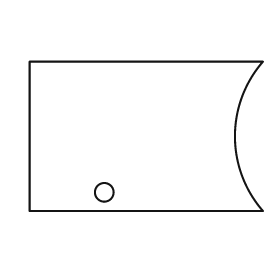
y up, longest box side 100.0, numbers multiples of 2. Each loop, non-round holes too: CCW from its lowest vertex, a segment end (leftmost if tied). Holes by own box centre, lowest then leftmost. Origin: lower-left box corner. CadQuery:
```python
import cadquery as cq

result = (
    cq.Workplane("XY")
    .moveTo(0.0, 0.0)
    .lineTo(100.0, 0.0)
    .threePointArc((88.0, 32.0), (100.0, 64.0))
    .lineTo(0.0, 64.0)
    .close()
    .moveTo(32.0, 8.0)
    .circle(4.0)
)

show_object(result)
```